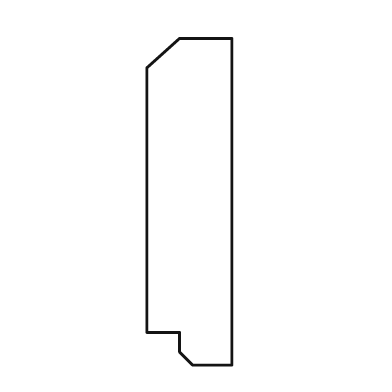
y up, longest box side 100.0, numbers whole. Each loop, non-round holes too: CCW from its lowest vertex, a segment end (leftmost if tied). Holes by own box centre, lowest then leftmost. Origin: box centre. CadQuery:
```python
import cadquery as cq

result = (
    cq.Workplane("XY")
    .moveTo(1.0, -50.0)
    .lineTo(13.0, -50.0)
    .lineTo(13.0, 50.0)
    .lineTo(-3.0, 50.0)
    .lineTo(-13.0, 41.0)
    .lineTo(-13.0, -40.0)
    .lineTo(-3.0, -40.0)
    .lineTo(-3.0, -46.0)
    .close()
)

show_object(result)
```